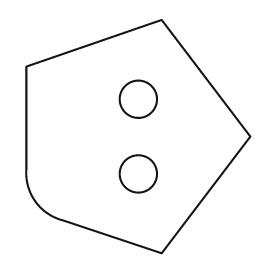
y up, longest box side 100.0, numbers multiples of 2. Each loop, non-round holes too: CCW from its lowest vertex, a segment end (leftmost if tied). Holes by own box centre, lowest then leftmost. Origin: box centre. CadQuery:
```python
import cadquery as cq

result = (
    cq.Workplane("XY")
    .moveTo(10.0, -50.0)
    .lineTo(48.0, 0.0)
    .lineTo(10.0, 50.0)
    .lineTo(-48.0, 30.0)
    .lineTo(-48.0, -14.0)
    .threePointArc((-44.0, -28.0), (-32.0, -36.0))
    .close()
    .moveTo(0.0, -16.0)
    .circle(8.0)
    .moveTo(0.0, 16.0)
    .circle(8.0)
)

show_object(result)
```